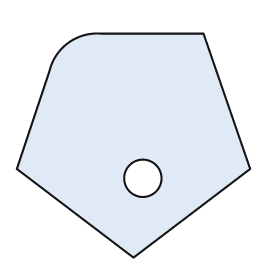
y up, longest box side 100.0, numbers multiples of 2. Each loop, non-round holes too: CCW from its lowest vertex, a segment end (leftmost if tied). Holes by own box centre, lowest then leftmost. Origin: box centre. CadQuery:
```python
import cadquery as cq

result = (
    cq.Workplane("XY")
    .moveTo(0.0, -48.0)
    .lineTo(50.0, -10.0)
    .lineTo(30.0, 48.0)
    .lineTo(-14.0, 48.0)
    .threePointArc((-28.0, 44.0), (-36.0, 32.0))
    .lineTo(-50.0, -10.0)
    .close()
    .moveTo(4.0, -14.0)
    .circle(8.0)
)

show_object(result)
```